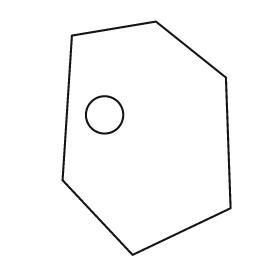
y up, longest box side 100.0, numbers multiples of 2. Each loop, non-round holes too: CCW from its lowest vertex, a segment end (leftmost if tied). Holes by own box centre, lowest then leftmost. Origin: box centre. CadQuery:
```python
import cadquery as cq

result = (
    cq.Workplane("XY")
    .moveTo(-6.0, -50.0)
    .lineTo(36.0, -30.0)
    .lineTo(34.0, 26.0)
    .lineTo(4.0, 50.0)
    .lineTo(-32.0, 44.0)
    .lineTo(-36.0, -18.0)
    .close()
    .moveTo(-18.0, 10.0)
    .circle(8.0)
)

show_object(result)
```